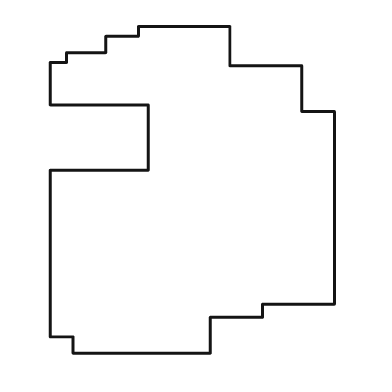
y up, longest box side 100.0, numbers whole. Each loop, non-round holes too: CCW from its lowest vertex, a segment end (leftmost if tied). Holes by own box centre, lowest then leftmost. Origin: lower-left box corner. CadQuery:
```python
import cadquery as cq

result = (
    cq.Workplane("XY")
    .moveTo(7.0, 0.0)
    .lineTo(49.0, 0.0)
    .lineTo(49.0, 11.0)
    .lineTo(65.0, 11.0)
    .lineTo(65.0, 15.0)
    .lineTo(87.0, 15.0)
    .lineTo(87.0, 74.0)
    .lineTo(77.0, 74.0)
    .lineTo(77.0, 88.0)
    .lineTo(55.0, 88.0)
    .lineTo(55.0, 100.0)
    .lineTo(27.0, 100.0)
    .lineTo(27.0, 97.0)
    .lineTo(17.0, 97.0)
    .lineTo(17.0, 92.0)
    .lineTo(5.0, 92.0)
    .lineTo(5.0, 89.0)
    .lineTo(0.0, 89.0)
    .lineTo(0.0, 76.0)
    .lineTo(30.0, 76.0)
    .lineTo(30.0, 56.0)
    .lineTo(0.0, 56.0)
    .lineTo(0.0, 5.0)
    .lineTo(7.0, 5.0)
    .close()
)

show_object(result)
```